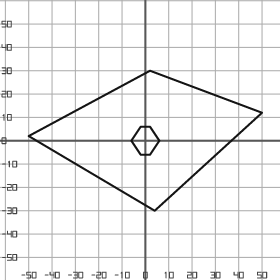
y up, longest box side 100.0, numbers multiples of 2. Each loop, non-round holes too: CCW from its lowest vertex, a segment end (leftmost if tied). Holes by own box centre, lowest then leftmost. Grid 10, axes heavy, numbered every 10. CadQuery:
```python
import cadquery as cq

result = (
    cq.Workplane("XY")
    .moveTo(4.0, -30.0)
    .lineTo(50.0, 12.0)
    .lineTo(2.0, 30.0)
    .lineTo(-50.0, 2.0)
    .close()
    .moveTo(-2.0, -6.0)
    .lineTo(2.0, -6.0)
    .lineTo(6.0, 0.0)
    .lineTo(2.0, 6.0)
    .lineTo(-2.0, 6.0)
    .lineTo(-6.0, 0.0)
    .close()
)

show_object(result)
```